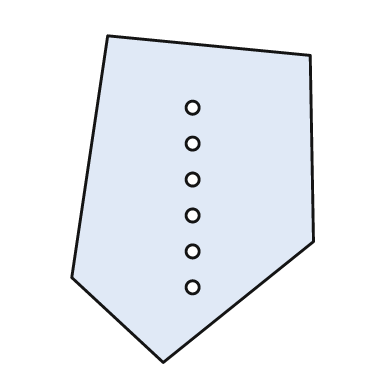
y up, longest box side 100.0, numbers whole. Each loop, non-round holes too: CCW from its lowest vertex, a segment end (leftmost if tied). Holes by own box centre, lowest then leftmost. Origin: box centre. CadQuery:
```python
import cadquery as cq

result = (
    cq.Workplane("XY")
    .moveTo(-9.0, -50.0)
    .lineTo(37.0, -13.0)
    .lineTo(36.0, 44.0)
    .lineTo(-26.0, 50.0)
    .lineTo(-37.0, -24.0)
    .close()
    .moveTo(0.0, -27.0)
    .circle(2.0)
    .moveTo(0.0, -16.0)
    .circle(2.0)
    .moveTo(0.0, -5.0)
    .circle(2.0)
    .moveTo(0.0, 6.0)
    .circle(2.0)
    .moveTo(0.0, 17.0)
    .circle(2.0)
    .moveTo(0.0, 28.0)
    .circle(2.0)
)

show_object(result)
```